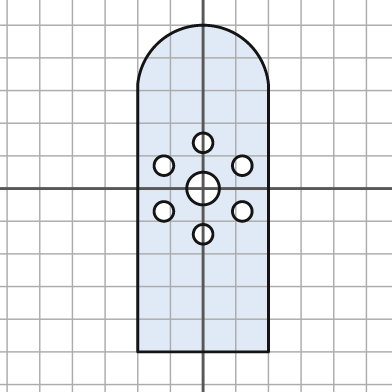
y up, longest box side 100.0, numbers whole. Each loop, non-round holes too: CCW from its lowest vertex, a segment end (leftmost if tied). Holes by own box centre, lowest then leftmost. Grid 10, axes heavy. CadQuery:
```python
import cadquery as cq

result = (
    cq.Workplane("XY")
    .moveTo(-20.0, -50.0)
    .lineTo(20.0, -50.0)
    .lineTo(20.0, 32.0)
    .threePointArc((0.0, 50.0), (-20.0, 32.0))
    .close()
    .moveTo(0.0, -14.0)
    .circle(3.0)
    .moveTo(-12.0, -7.0)
    .circle(3.0)
    .moveTo(12.0, -7.0)
    .circle(3.0)
    .moveTo(0.0, 0.0)
    .circle(5.0)
    .moveTo(-12.0, 7.0)
    .circle(3.0)
    .moveTo(12.0, 7.0)
    .circle(3.0)
    .moveTo(0.0, 14.0)
    .circle(3.0)
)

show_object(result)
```